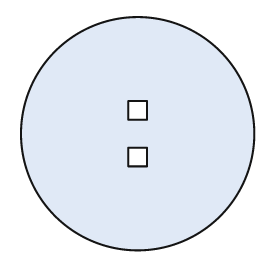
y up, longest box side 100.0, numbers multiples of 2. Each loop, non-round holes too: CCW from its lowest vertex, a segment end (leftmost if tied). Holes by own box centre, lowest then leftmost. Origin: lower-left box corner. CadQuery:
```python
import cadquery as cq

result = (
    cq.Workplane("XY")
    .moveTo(50.0, 50.0)
    .circle(50.0)
    .moveTo(46.0, 36.0)
    .lineTo(54.0, 36.0)
    .lineTo(54.0, 44.0)
    .lineTo(46.0, 44.0)
    .close()
    .moveTo(46.0, 56.0)
    .lineTo(54.0, 56.0)
    .lineTo(54.0, 64.0)
    .lineTo(46.0, 64.0)
    .close()
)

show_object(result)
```